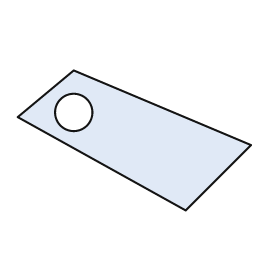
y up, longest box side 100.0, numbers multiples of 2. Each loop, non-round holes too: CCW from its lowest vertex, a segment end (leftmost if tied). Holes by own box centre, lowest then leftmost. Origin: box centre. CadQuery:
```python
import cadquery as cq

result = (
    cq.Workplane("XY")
    .moveTo(22.0, -30.0)
    .lineTo(50.0, -2.0)
    .lineTo(-26.0, 30.0)
    .lineTo(-50.0, 10.0)
    .close()
    .moveTo(-26.0, 12.0)
    .circle(8.0)
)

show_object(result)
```